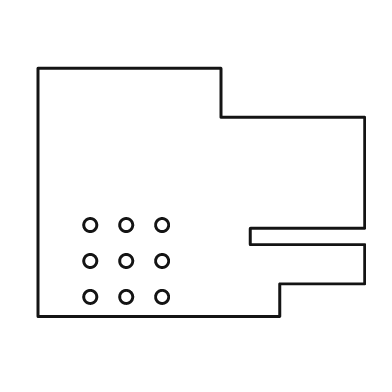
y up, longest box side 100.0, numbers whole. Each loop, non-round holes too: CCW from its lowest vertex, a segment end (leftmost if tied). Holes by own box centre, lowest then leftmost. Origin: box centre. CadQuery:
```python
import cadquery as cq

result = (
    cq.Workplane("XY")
    .moveTo(-50.0, -38.0)
    .lineTo(24.0, -38.0)
    .lineTo(24.0, -28.0)
    .lineTo(50.0, -28.0)
    .lineTo(50.0, -16.0)
    .lineTo(15.0, -16.0)
    .lineTo(15.0, -11.0)
    .lineTo(50.0, -11.0)
    .lineTo(50.0, 23.0)
    .lineTo(6.0, 23.0)
    .lineTo(6.0, 38.0)
    .lineTo(-50.0, 38.0)
    .close()
    .moveTo(-34.0, -32.0)
    .circle(2.0)
    .moveTo(-23.0, -32.0)
    .circle(2.0)
    .moveTo(-12.0, -32.0)
    .circle(2.0)
    .moveTo(-34.0, -21.0)
    .circle(2.0)
    .moveTo(-23.0, -21.0)
    .circle(2.0)
    .moveTo(-12.0, -21.0)
    .circle(2.0)
    .moveTo(-34.0, -10.0)
    .circle(2.0)
    .moveTo(-23.0, -10.0)
    .circle(2.0)
    .moveTo(-12.0, -10.0)
    .circle(2.0)
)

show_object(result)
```